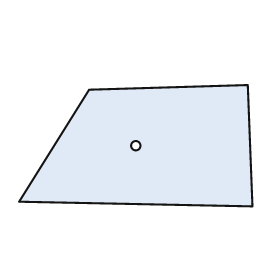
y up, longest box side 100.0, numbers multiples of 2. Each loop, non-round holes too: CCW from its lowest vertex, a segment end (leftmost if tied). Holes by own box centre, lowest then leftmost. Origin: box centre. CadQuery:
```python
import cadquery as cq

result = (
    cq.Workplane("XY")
    .moveTo(50.0, -26.0)
    .lineTo(48.0, 26.0)
    .lineTo(-20.0, 24.0)
    .lineTo(-50.0, -24.0)
    .close()
    .moveTo(0.0, 0.0)
    .circle(2.0)
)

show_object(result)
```